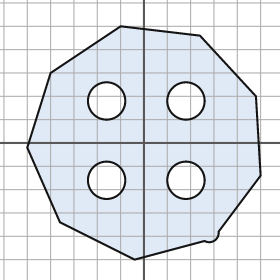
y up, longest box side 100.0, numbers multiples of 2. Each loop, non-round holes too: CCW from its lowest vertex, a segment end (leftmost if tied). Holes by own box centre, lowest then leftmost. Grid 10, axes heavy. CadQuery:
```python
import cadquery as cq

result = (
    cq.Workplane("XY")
    .moveTo(-4.0, -50.0)
    .lineTo(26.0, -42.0)
    .threePointArc((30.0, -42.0), (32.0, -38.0))
    .lineTo(50.0, -14.0)
    .lineTo(48.0, 20.0)
    .lineTo(24.0, 46.0)
    .lineTo(-10.0, 50.0)
    .lineTo(-40.0, 30.0)
    .lineTo(-50.0, -2.0)
    .lineTo(-36.0, -34.0)
    .close()
    .moveTo(-16.0, -16.0)
    .circle(8.0)
    .moveTo(18.0, -16.0)
    .circle(8.0)
    .moveTo(-16.0, 18.0)
    .circle(8.0)
    .moveTo(18.0, 18.0)
    .circle(8.0)
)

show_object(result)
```